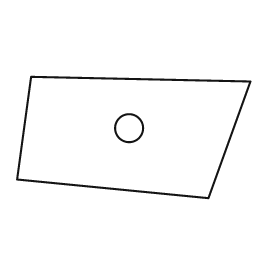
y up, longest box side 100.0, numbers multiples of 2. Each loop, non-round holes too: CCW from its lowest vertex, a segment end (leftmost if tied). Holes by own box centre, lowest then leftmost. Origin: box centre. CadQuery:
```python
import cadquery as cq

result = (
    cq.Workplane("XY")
    .moveTo(32.0, -26.0)
    .lineTo(50.0, 24.0)
    .lineTo(-44.0, 26.0)
    .lineTo(-50.0, -18.0)
    .close()
    .moveTo(-2.0, 4.0)
    .circle(6.0)
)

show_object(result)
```